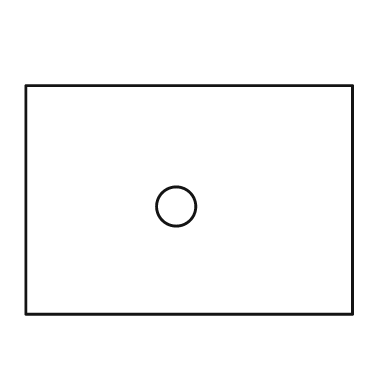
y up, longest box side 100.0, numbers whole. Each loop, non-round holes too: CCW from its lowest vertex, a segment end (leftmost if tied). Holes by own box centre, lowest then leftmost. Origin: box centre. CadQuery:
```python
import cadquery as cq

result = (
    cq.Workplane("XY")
    .moveTo(-50.0, -35.0)
    .lineTo(50.0, -35.0)
    .lineTo(50.0, 35.0)
    .lineTo(-50.0, 35.0)
    .close()
    .moveTo(-4.0, -2.0)
    .circle(6.0)
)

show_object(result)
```